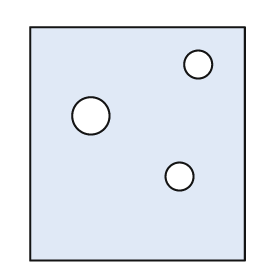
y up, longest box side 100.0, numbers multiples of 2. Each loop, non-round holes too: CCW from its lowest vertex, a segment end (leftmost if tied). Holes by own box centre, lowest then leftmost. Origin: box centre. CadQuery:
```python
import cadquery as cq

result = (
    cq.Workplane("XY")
    .moveTo(-46.0, -50.0)
    .lineTo(46.0, -50.0)
    .lineTo(46.0, 50.0)
    .lineTo(-46.0, 50.0)
    .close()
    .moveTo(18.0, -14.0)
    .circle(6.0)
    .moveTo(-20.0, 12.0)
    .circle(8.0)
    .moveTo(26.0, 34.0)
    .circle(6.0)
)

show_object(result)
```